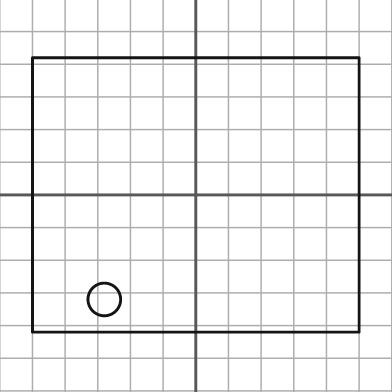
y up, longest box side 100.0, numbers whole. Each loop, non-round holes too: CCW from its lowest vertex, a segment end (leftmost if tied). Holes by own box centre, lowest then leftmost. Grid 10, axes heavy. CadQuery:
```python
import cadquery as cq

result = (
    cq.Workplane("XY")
    .moveTo(-50.0, -42.0)
    .lineTo(50.0, -42.0)
    .lineTo(50.0, 42.0)
    .lineTo(-50.0, 42.0)
    .close()
    .moveTo(-28.0, -32.0)
    .circle(5.0)
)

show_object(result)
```